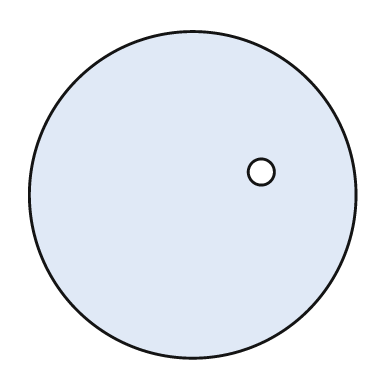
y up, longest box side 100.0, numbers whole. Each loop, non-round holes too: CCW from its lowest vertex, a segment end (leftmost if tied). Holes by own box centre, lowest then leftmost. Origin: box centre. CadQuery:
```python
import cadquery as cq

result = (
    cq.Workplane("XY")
    .moveTo(0.0, 0.0)
    .circle(50.0)
    .moveTo(21.0, 7.0)
    .circle(4.0)
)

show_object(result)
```